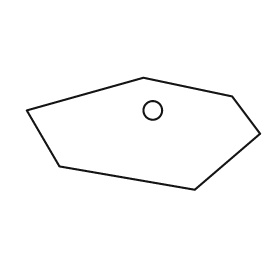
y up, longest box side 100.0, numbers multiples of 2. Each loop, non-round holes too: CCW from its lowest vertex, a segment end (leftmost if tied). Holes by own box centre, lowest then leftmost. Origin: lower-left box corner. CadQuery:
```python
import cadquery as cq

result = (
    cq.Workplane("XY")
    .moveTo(72.0, 0.0)
    .lineTo(100.0, 24.0)
    .lineTo(88.0, 40.0)
    .lineTo(50.0, 48.0)
    .lineTo(0.0, 34.0)
    .lineTo(14.0, 10.0)
    .close()
    .moveTo(54.0, 34.0)
    .circle(4.0)
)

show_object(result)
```